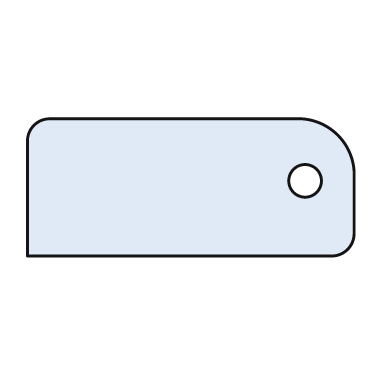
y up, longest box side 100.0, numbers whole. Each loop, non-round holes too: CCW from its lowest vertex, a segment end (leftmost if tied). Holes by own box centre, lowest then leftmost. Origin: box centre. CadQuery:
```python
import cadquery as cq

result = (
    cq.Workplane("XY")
    .moveTo(-50.0, -21.0)
    .lineTo(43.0, -21.0)
    .threePointArc((48.0, -19.0), (50.0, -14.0))
    .lineTo(50.0, 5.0)
    .threePointArc((45.0, 16.0), (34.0, 21.0))
    .lineTo(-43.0, 21.0)
    .threePointArc((-48.0, 19.0), (-50.0, 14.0))
    .close()
    .moveTo(35.0, 2.0)
    .circle(5.0)
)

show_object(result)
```